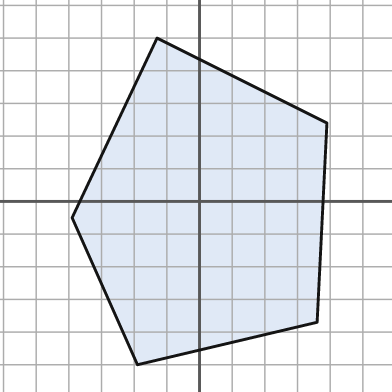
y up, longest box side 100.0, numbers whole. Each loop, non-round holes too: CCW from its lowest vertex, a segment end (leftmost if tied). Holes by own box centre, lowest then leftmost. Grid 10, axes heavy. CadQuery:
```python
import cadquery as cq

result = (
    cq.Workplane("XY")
    .moveTo(-19.0, -50.0)
    .lineTo(36.0, -37.0)
    .lineTo(39.0, 24.0)
    .lineTo(-13.0, 50.0)
    .lineTo(-39.0, -5.0)
    .close()
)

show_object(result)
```